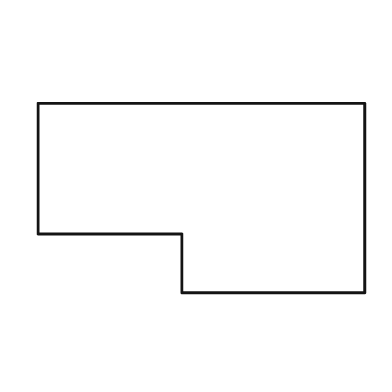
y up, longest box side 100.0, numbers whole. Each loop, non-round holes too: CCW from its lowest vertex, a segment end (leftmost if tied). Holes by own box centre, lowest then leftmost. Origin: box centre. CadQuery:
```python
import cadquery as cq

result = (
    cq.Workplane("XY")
    .moveTo(-6.0, -29.0)
    .lineTo(50.0, -29.0)
    .lineTo(50.0, 29.0)
    .lineTo(-50.0, 29.0)
    .lineTo(-50.0, -11.0)
    .lineTo(-6.0, -11.0)
    .close()
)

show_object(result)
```